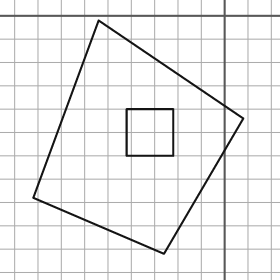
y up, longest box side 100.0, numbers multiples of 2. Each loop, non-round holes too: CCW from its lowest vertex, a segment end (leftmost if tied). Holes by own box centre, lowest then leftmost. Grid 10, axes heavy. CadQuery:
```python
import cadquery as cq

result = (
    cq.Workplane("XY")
    .moveTo(-26.0, -102.0)
    .lineTo(8.0, -44.0)
    .lineTo(-54.0, -2.0)
    .lineTo(-82.0, -78.0)
    .close()
    .moveTo(-42.0, -60.0)
    .lineTo(-22.0, -60.0)
    .lineTo(-22.0, -40.0)
    .lineTo(-42.0, -40.0)
    .close()
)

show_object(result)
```